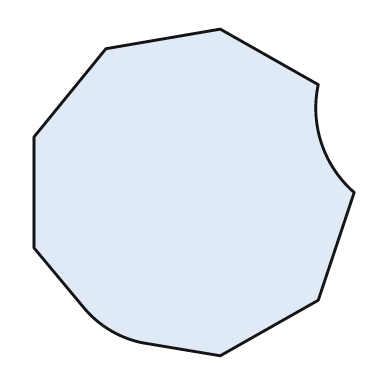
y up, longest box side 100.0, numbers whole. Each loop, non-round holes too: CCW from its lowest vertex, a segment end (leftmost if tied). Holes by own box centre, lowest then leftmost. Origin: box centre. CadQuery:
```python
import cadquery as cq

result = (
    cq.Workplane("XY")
    .moveTo(8.0, -50.0)
    .lineTo(38.0, -33.0)
    .lineTo(49.0, 0.0)
    .threePointArc((39.0, 15.0), (38.0, 33.0))
    .lineTo(8.0, 50.0)
    .lineTo(-27.0, 44.0)
    .lineTo(-49.0, 17.0)
    .lineTo(-49.0, -17.0)
    .lineTo(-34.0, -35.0)
    .threePointArc((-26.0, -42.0), (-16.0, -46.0))
    .close()
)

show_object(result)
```